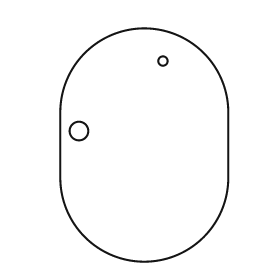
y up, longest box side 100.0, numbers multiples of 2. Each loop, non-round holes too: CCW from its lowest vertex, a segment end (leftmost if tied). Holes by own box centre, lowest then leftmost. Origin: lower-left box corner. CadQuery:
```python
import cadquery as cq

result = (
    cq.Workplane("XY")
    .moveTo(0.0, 36.0)
    .threePointArc((36.0, 0.0), (72.0, 36.0))
    .lineTo(72.0, 64.0)
    .threePointArc((36.0, 100.0), (0.0, 64.0))
    .close()
    .moveTo(8.0, 56.0)
    .circle(4.0)
    .moveTo(44.0, 86.0)
    .circle(2.0)
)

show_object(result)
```